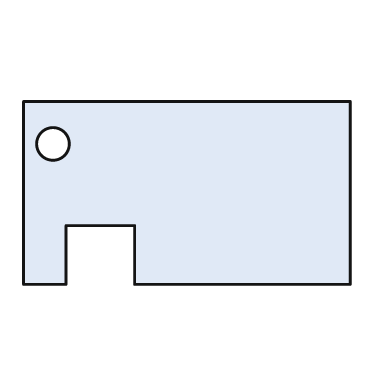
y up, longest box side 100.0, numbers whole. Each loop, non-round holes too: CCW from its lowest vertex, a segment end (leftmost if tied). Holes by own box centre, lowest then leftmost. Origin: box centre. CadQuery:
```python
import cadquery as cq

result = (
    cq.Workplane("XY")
    .moveTo(-50.0, -28.0)
    .lineTo(-37.0, -28.0)
    .lineTo(-37.0, -10.0)
    .lineTo(-16.0, -10.0)
    .lineTo(-16.0, -28.0)
    .lineTo(50.0, -28.0)
    .lineTo(50.0, 28.0)
    .lineTo(-50.0, 28.0)
    .close()
    .moveTo(-41.0, 15.0)
    .circle(5.0)
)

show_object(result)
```